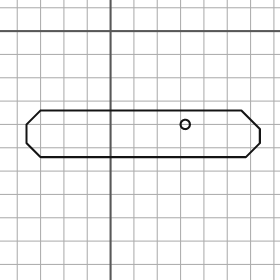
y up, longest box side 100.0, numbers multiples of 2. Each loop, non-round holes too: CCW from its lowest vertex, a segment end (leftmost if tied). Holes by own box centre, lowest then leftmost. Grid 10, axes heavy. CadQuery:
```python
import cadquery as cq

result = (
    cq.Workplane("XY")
    .moveTo(-30.0, -54.0)
    .lineTo(58.0, -54.0)
    .lineTo(64.0, -48.0)
    .lineTo(64.0, -42.0)
    .lineTo(56.0, -34.0)
    .lineTo(-30.0, -34.0)
    .lineTo(-36.0, -40.0)
    .lineTo(-36.0, -48.0)
    .close()
    .moveTo(32.0, -40.0)
    .circle(2.0)
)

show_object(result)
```